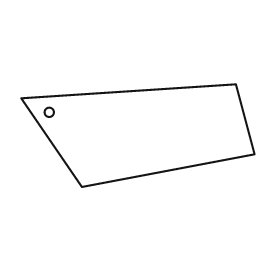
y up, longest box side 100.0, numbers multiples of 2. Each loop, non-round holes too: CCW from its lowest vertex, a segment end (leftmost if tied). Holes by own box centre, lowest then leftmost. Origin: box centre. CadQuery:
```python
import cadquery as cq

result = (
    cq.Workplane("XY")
    .moveTo(-24.0, -22.0)
    .lineTo(50.0, -8.0)
    .lineTo(42.0, 22.0)
    .lineTo(-50.0, 16.0)
    .close()
    .moveTo(-38.0, 10.0)
    .circle(2.0)
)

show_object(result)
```